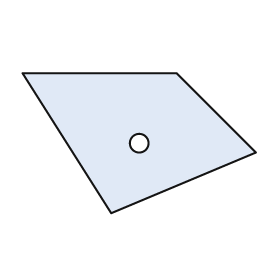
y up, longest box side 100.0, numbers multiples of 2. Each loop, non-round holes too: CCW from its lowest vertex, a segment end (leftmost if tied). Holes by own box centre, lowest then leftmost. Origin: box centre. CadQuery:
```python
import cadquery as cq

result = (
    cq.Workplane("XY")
    .moveTo(-12.0, -30.0)
    .lineTo(50.0, -4.0)
    .lineTo(16.0, 30.0)
    .lineTo(-50.0, 30.0)
    .close()
    .moveTo(0.0, 0.0)
    .circle(4.0)
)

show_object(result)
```